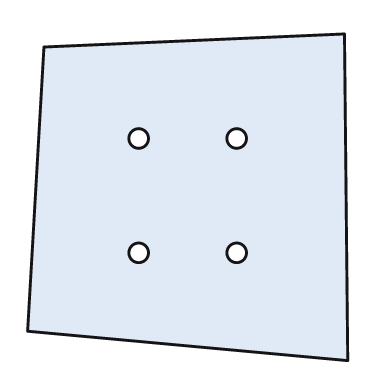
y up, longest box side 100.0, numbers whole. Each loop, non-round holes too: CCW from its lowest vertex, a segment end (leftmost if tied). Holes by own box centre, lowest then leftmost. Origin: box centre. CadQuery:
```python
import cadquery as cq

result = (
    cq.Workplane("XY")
    .moveTo(49.0, -50.0)
    .lineTo(48.0, 50.0)
    .lineTo(-44.0, 46.0)
    .lineTo(-49.0, -41.0)
    .close()
    .moveTo(-15.0, -17.0)
    .circle(3.0)
    .moveTo(15.0, -17.0)
    .circle(3.0)
    .moveTo(-15.0, 18.0)
    .circle(3.0)
    .moveTo(15.0, 18.0)
    .circle(3.0)
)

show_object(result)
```